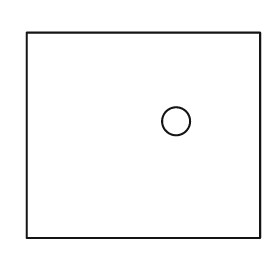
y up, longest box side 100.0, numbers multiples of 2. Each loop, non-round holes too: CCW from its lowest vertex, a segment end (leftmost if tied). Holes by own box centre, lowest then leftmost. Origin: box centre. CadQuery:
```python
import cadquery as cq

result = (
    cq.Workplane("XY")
    .moveTo(-50.0, -44.0)
    .lineTo(50.0, -44.0)
    .lineTo(50.0, 44.0)
    .lineTo(-50.0, 44.0)
    .close()
    .moveTo(14.0, 6.0)
    .circle(6.0)
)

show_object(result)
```